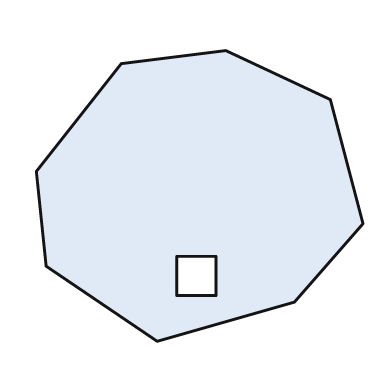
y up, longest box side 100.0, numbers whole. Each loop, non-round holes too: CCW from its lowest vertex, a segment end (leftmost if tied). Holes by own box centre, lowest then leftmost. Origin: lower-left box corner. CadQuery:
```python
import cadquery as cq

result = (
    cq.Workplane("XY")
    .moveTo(37.0, 0.0)
    .lineTo(79.0, 12.0)
    .lineTo(100.0, 36.0)
    .lineTo(90.0, 74.0)
    .lineTo(58.0, 89.0)
    .lineTo(26.0, 85.0)
    .lineTo(0.0, 52.0)
    .lineTo(3.0, 23.0)
    .close()
    .moveTo(43.0, 14.0)
    .lineTo(55.0, 14.0)
    .lineTo(55.0, 26.0)
    .lineTo(43.0, 26.0)
    .close()
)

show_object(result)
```